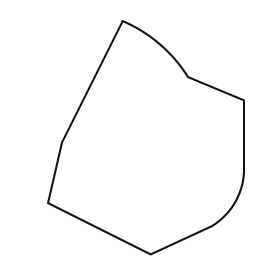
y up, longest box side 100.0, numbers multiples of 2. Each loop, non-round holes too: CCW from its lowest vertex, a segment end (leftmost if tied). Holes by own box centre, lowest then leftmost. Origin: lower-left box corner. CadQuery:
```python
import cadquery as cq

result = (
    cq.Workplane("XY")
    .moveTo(44.0, 0.0)
    .lineTo(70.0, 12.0)
    .threePointArc((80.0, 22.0), (84.0, 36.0))
    .lineTo(84.0, 66.0)
    .lineTo(60.0, 76.0)
    .threePointArc((48.0, 90.0), (32.0, 100.0))
    .lineTo(6.0, 48.0)
    .lineTo(0.0, 22.0)
    .close()
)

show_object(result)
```